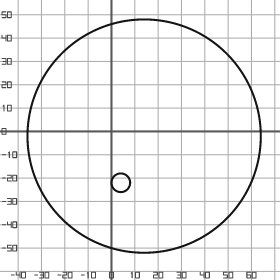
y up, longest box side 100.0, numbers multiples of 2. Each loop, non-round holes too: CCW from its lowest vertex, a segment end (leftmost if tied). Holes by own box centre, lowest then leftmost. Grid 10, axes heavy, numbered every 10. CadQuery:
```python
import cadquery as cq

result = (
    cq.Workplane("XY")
    .moveTo(14.0, -2.0)
    .circle(50.0)
    .moveTo(4.0, -22.0)
    .circle(4.0)
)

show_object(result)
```